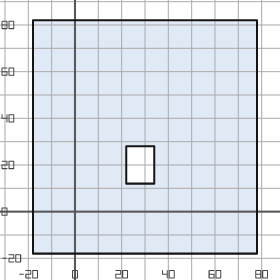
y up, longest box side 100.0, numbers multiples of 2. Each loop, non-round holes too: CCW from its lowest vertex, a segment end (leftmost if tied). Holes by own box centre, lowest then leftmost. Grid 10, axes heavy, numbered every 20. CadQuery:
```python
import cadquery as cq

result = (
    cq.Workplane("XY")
    .moveTo(-18.0, -18.0)
    .lineTo(78.0, -18.0)
    .lineTo(78.0, 82.0)
    .lineTo(-18.0, 82.0)
    .close()
    .moveTo(22.0, 12.0)
    .lineTo(34.0, 12.0)
    .lineTo(34.0, 28.0)
    .lineTo(22.0, 28.0)
    .close()
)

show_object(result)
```